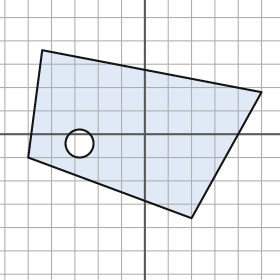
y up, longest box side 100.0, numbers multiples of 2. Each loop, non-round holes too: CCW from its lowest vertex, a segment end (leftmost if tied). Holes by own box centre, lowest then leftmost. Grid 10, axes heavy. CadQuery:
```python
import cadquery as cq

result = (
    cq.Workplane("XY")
    .moveTo(20.0, -36.0)
    .lineTo(50.0, 18.0)
    .lineTo(-44.0, 36.0)
    .lineTo(-50.0, -10.0)
    .close()
    .moveTo(-28.0, -4.0)
    .circle(6.0)
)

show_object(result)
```